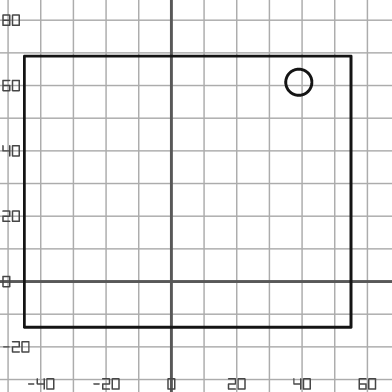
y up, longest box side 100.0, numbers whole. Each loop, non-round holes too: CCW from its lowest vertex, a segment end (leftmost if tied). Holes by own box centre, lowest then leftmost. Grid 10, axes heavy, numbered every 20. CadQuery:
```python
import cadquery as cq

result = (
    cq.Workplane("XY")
    .moveTo(-45.0, -14.0)
    .lineTo(55.0, -14.0)
    .lineTo(55.0, 69.0)
    .lineTo(-45.0, 69.0)
    .close()
    .moveTo(39.0, 61.0)
    .circle(4.0)
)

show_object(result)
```